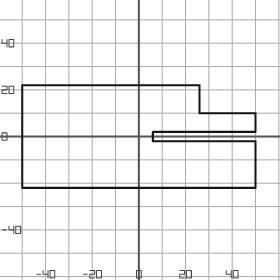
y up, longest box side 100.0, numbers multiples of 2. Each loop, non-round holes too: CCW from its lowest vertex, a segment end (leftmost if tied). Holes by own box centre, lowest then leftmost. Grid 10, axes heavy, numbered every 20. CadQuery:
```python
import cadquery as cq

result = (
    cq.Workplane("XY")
    .moveTo(-50.0, -22.0)
    .lineTo(50.0, -22.0)
    .lineTo(50.0, -2.0)
    .lineTo(6.0, -2.0)
    .lineTo(6.0, 2.0)
    .lineTo(50.0, 2.0)
    .lineTo(50.0, 10.0)
    .lineTo(26.0, 10.0)
    .lineTo(26.0, 22.0)
    .lineTo(-50.0, 22.0)
    .close()
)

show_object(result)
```